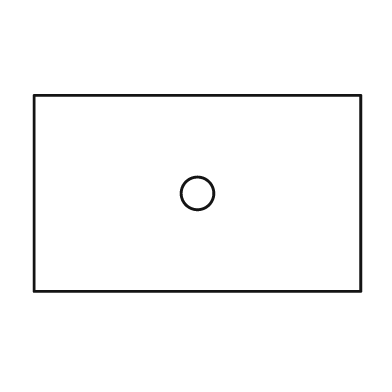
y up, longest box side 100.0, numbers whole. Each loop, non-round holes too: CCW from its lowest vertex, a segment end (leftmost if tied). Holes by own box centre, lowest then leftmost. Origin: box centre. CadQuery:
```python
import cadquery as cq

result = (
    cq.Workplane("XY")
    .moveTo(-50.0, -30.0)
    .lineTo(50.0, -30.0)
    .lineTo(50.0, 30.0)
    .lineTo(-50.0, 30.0)
    .close()
    .moveTo(0.0, 0.0)
    .circle(5.0)
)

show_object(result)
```